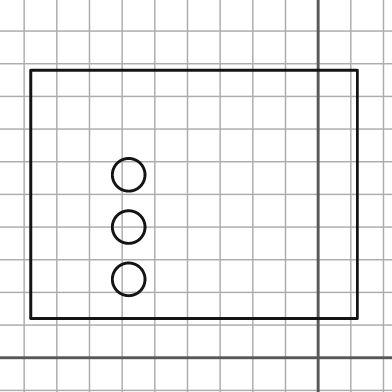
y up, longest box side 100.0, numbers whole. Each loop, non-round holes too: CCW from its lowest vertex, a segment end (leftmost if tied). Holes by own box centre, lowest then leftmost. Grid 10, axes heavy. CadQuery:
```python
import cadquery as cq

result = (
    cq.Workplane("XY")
    .moveTo(-88.0, 12.0)
    .lineTo(12.0, 12.0)
    .lineTo(12.0, 88.0)
    .lineTo(-88.0, 88.0)
    .close()
    .moveTo(-58.0, 24.0)
    .circle(5.0)
    .moveTo(-58.0, 40.0)
    .circle(5.0)
    .moveTo(-58.0, 56.0)
    .circle(5.0)
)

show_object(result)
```